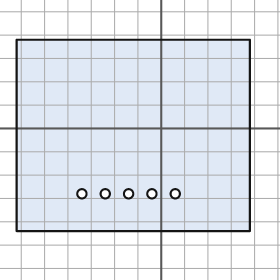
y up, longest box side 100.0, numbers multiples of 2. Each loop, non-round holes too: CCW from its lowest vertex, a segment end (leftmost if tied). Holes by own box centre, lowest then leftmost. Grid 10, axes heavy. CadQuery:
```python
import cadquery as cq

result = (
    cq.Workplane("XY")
    .moveTo(-62.0, -44.0)
    .lineTo(38.0, -44.0)
    .lineTo(38.0, 38.0)
    .lineTo(-62.0, 38.0)
    .close()
    .moveTo(-34.0, -28.0)
    .circle(2.0)
    .moveTo(-24.0, -28.0)
    .circle(2.0)
    .moveTo(-14.0, -28.0)
    .circle(2.0)
    .moveTo(-4.0, -28.0)
    .circle(2.0)
    .moveTo(6.0, -28.0)
    .circle(2.0)
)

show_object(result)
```